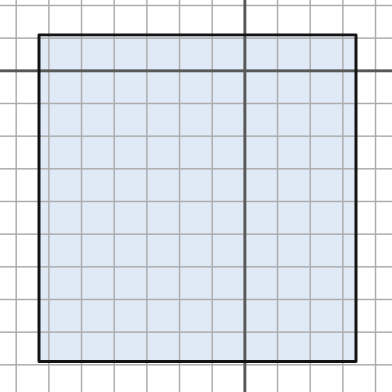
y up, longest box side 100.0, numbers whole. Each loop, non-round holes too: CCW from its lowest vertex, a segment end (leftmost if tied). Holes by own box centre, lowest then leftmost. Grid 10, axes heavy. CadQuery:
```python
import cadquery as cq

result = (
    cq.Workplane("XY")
    .moveTo(-63.0, -89.0)
    .lineTo(34.0, -89.0)
    .lineTo(34.0, 11.0)
    .lineTo(-63.0, 11.0)
    .close()
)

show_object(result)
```